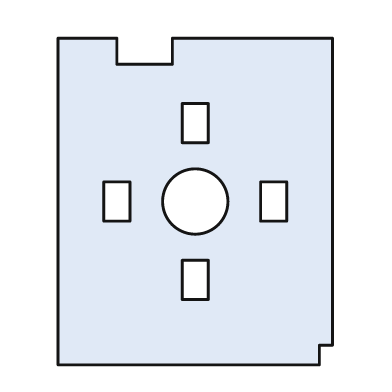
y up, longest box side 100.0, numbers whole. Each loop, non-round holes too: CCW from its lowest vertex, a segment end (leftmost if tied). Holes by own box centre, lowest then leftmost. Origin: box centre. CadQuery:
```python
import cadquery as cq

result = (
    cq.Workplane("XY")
    .moveTo(-42.0, -50.0)
    .lineTo(38.0, -50.0)
    .lineTo(38.0, -44.0)
    .lineTo(42.0, -44.0)
    .lineTo(42.0, 50.0)
    .lineTo(-7.0, 50.0)
    .lineTo(-7.0, 42.0)
    .lineTo(-24.0, 42.0)
    .lineTo(-24.0, 50.0)
    .lineTo(-42.0, 50.0)
    .close()
    .moveTo(-4.0, -30.0)
    .lineTo(4.0, -30.0)
    .lineTo(4.0, -18.0)
    .lineTo(-4.0, -18.0)
    .close()
    .moveTo(-28.0, -6.0)
    .lineTo(-20.0, -6.0)
    .lineTo(-20.0, 6.0)
    .lineTo(-28.0, 6.0)
    .close()
    .moveTo(0.0, 0.0)
    .circle(10.0)
    .moveTo(20.0, -6.0)
    .lineTo(28.0, -6.0)
    .lineTo(28.0, 6.0)
    .lineTo(20.0, 6.0)
    .close()
    .moveTo(-4.0, 18.0)
    .lineTo(4.0, 18.0)
    .lineTo(4.0, 30.0)
    .lineTo(-4.0, 30.0)
    .close()
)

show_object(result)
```